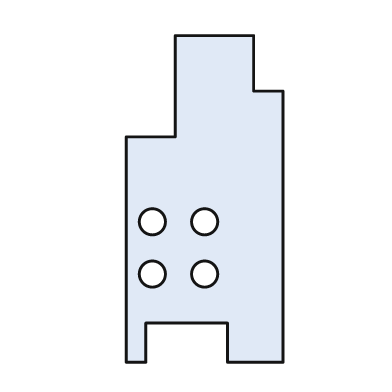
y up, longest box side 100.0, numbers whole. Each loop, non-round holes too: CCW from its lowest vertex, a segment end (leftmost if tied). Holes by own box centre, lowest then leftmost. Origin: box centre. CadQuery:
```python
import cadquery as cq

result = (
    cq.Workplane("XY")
    .moveTo(-24.0, -50.0)
    .lineTo(-18.0, -50.0)
    .lineTo(-18.0, -38.0)
    .lineTo(7.0, -38.0)
    .lineTo(7.0, -50.0)
    .lineTo(24.0, -50.0)
    .lineTo(24.0, 33.0)
    .lineTo(15.0, 33.0)
    .lineTo(15.0, 50.0)
    .lineTo(-9.0, 50.0)
    .lineTo(-9.0, 19.0)
    .lineTo(-24.0, 19.0)
    .close()
    .moveTo(-16.0, -23.0)
    .circle(4.0)
    .moveTo(0.0, -23.0)
    .circle(4.0)
    .moveTo(-16.0, -7.0)
    .circle(4.0)
    .moveTo(0.0, -7.0)
    .circle(4.0)
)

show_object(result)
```